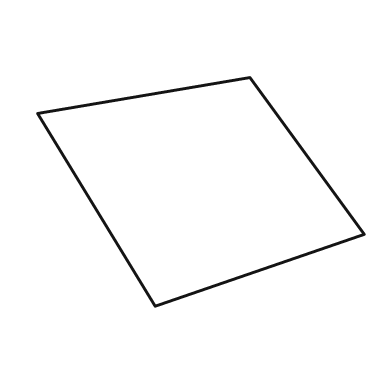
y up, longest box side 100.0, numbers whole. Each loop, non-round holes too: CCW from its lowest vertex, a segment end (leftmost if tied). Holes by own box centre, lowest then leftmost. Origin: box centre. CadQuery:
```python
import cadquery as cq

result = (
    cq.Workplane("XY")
    .moveTo(-14.0, -35.0)
    .lineTo(50.0, -13.0)
    .lineTo(15.0, 35.0)
    .lineTo(-50.0, 24.0)
    .close()
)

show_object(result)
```